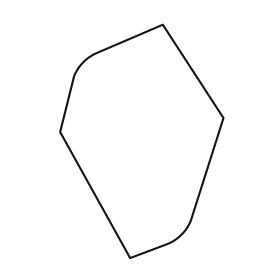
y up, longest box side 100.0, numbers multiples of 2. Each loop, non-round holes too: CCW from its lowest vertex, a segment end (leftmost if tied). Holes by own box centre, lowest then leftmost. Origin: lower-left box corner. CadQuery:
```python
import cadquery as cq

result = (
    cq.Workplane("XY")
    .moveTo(30.0, 0.0)
    .lineTo(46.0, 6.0)
    .threePointArc((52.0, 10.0), (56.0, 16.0))
    .lineTo(70.0, 60.0)
    .lineTo(44.0, 100.0)
    .lineTo(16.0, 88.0)
    .threePointArc((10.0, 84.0), (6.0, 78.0))
    .lineTo(0.0, 54.0)
    .close()
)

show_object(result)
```